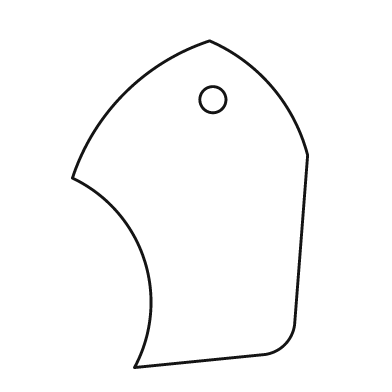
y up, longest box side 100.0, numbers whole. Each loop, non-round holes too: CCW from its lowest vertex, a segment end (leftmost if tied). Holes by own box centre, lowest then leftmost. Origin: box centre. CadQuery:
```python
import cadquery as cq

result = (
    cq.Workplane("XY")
    .moveTo(-17.0, -50.0)
    .lineTo(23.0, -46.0)
    .threePointArc((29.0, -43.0), (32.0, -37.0))
    .lineTo(36.0, 15.0)
    .threePointArc((25.0, 36.0), (6.0, 50.0))
    .threePointArc((-20.0, 34.0), (-36.0, 8.0))
    .threePointArc((-14.0, -17.0), (-17.0, -50.0))
    .close()
    .moveTo(7.0, 32.0)
    .circle(4.0)
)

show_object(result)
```